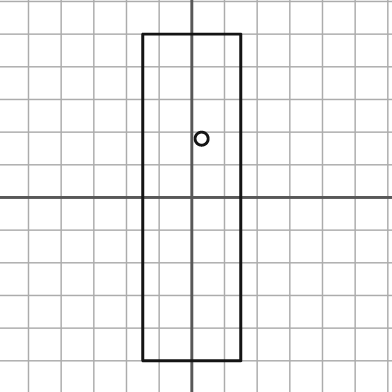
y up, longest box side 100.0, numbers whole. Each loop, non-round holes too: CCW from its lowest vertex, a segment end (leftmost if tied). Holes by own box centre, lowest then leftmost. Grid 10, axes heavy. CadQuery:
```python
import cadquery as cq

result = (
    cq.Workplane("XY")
    .moveTo(-15.0, -50.0)
    .lineTo(15.0, -50.0)
    .lineTo(15.0, 50.0)
    .lineTo(-15.0, 50.0)
    .close()
    .moveTo(3.0, 18.0)
    .circle(2.0)
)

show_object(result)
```